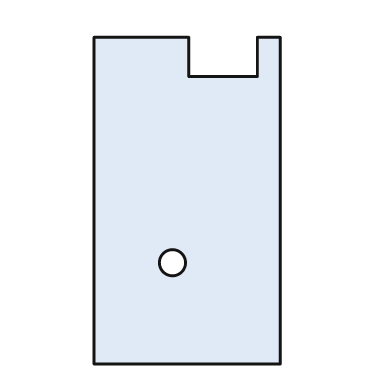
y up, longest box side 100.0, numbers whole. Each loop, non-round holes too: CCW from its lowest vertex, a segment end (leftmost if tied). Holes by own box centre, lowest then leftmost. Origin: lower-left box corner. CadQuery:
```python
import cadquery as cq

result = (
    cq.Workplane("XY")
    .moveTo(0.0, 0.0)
    .lineTo(57.0, 0.0)
    .lineTo(57.0, 100.0)
    .lineTo(50.0, 100.0)
    .lineTo(50.0, 88.0)
    .lineTo(29.0, 88.0)
    .lineTo(29.0, 100.0)
    .lineTo(0.0, 100.0)
    .close()
    .moveTo(24.0, 31.0)
    .circle(4.0)
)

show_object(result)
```